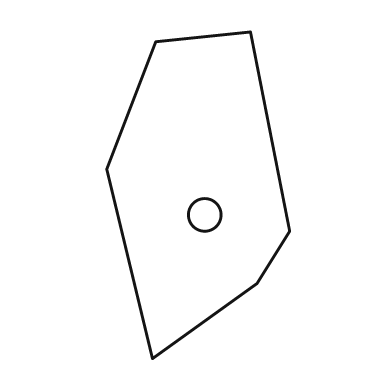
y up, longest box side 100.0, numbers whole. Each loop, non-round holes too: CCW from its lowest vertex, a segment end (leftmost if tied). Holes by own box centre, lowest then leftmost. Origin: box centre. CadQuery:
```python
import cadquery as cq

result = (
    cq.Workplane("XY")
    .moveTo(-14.0, -50.0)
    .lineTo(18.0, -27.0)
    .lineTo(28.0, -11.0)
    .lineTo(16.0, 50.0)
    .lineTo(-13.0, 47.0)
    .lineTo(-28.0, 8.0)
    .close()
    .moveTo(2.0, -6.0)
    .circle(5.0)
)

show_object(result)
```